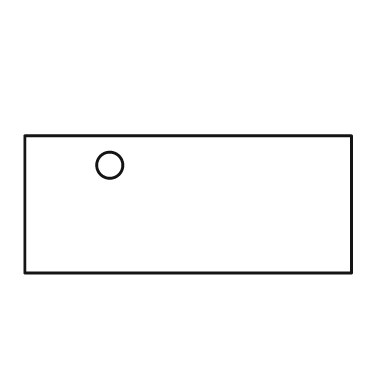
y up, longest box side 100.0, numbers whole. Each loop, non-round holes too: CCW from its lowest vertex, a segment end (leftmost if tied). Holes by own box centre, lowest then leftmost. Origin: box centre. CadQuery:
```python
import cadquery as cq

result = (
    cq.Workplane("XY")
    .moveTo(-50.0, -21.0)
    .lineTo(50.0, -21.0)
    .lineTo(50.0, 21.0)
    .lineTo(-50.0, 21.0)
    .close()
    .moveTo(-24.0, 12.0)
    .circle(4.0)
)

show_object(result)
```